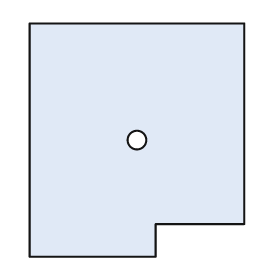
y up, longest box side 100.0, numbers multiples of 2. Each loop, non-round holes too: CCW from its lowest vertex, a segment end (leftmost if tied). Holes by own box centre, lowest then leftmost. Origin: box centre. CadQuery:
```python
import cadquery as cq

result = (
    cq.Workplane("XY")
    .moveTo(-46.0, -50.0)
    .lineTo(8.0, -50.0)
    .lineTo(8.0, -36.0)
    .lineTo(46.0, -36.0)
    .lineTo(46.0, 50.0)
    .lineTo(-46.0, 50.0)
    .close()
    .moveTo(0.0, 0.0)
    .circle(4.0)
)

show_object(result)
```